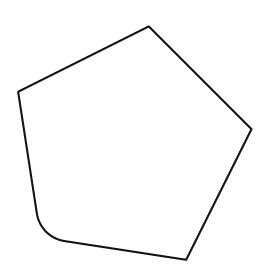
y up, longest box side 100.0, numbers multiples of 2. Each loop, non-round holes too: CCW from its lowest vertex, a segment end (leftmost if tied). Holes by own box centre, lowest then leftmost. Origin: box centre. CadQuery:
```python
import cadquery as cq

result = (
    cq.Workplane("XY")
    .moveTo(22.0, -50.0)
    .lineTo(50.0, 6.0)
    .lineTo(6.0, 50.0)
    .lineTo(-50.0, 22.0)
    .lineTo(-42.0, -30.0)
    .threePointArc((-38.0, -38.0), (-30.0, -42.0))
    .close()
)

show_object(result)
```